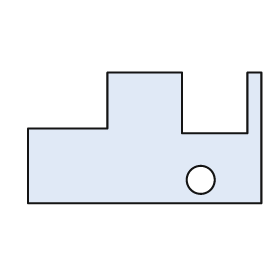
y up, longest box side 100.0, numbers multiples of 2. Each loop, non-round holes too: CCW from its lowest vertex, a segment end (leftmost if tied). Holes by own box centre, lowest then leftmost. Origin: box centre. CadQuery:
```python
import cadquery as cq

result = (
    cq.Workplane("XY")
    .moveTo(-50.0, -28.0)
    .lineTo(50.0, -28.0)
    .lineTo(50.0, 28.0)
    .lineTo(44.0, 28.0)
    .lineTo(44.0, 2.0)
    .lineTo(16.0, 2.0)
    .lineTo(16.0, 28.0)
    .lineTo(-16.0, 28.0)
    .lineTo(-16.0, 4.0)
    .lineTo(-50.0, 4.0)
    .close()
    .moveTo(24.0, -18.0)
    .circle(6.0)
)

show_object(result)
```